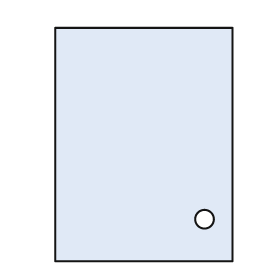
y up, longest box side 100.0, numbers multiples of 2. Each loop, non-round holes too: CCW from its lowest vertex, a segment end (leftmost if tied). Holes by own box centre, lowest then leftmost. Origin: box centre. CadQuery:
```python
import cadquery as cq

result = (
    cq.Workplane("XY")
    .moveTo(-38.0, -50.0)
    .lineTo(38.0, -50.0)
    .lineTo(38.0, 50.0)
    .lineTo(-38.0, 50.0)
    .close()
    .moveTo(26.0, -32.0)
    .circle(4.0)
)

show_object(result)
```